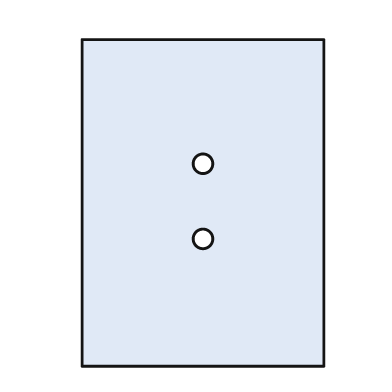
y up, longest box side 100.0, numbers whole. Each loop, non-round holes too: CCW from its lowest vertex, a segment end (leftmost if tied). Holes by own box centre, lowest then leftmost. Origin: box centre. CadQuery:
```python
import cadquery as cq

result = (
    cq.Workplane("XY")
    .moveTo(-37.0, -50.0)
    .lineTo(37.0, -50.0)
    .lineTo(37.0, 50.0)
    .lineTo(-37.0, 50.0)
    .close()
    .moveTo(0.0, -11.0)
    .circle(3.0)
    .moveTo(0.0, 12.0)
    .circle(3.0)
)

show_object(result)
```